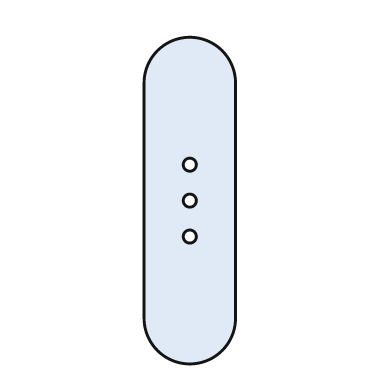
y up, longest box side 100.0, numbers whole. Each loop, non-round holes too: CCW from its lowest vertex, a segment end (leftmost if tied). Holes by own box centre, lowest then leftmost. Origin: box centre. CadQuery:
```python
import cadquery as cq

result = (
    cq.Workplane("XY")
    .moveTo(-14.0, -36.0)
    .threePointArc((0.0, -50.0), (14.0, -36.0))
    .lineTo(14.0, 36.0)
    .threePointArc((0.0, 50.0), (-14.0, 36.0))
    .close()
    .moveTo(0.0, -11.0)
    .circle(2.0)
    .moveTo(0.0, 0.0)
    .circle(2.0)
    .moveTo(0.0, 11.0)
    .circle(2.0)
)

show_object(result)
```